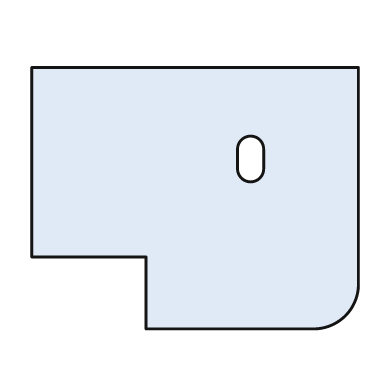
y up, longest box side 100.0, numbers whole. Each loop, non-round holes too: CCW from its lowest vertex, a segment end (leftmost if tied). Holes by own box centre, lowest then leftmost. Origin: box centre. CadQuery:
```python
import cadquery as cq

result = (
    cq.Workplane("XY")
    .moveTo(-15.0, -40.0)
    .lineTo(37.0, -40.0)
    .threePointArc((46.0, -36.0), (50.0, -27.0))
    .lineTo(50.0, 40.0)
    .lineTo(-50.0, 40.0)
    .lineTo(-50.0, -18.0)
    .lineTo(-15.0, -18.0)
    .close()
    .moveTo(13.0, 9.0)
    .threePointArc((17.0, 5.0), (21.0, 9.0))
    .lineTo(21.0, 15.0)
    .threePointArc((17.0, 19.0), (13.0, 15.0))
    .close()
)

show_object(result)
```